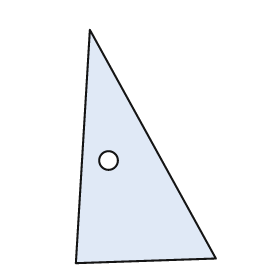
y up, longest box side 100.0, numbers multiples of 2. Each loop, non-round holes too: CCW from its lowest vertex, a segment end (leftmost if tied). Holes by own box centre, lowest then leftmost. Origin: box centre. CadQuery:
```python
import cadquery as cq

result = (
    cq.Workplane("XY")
    .moveTo(-30.0, -50.0)
    .lineTo(30.0, -48.0)
    .lineTo(-24.0, 50.0)
    .close()
    .moveTo(-16.0, -6.0)
    .circle(4.0)
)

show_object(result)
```